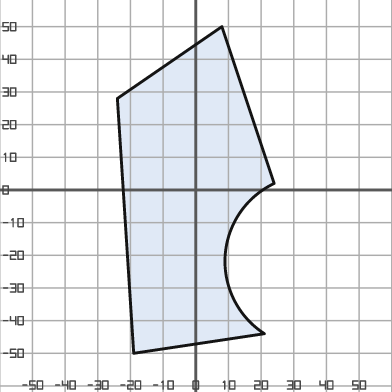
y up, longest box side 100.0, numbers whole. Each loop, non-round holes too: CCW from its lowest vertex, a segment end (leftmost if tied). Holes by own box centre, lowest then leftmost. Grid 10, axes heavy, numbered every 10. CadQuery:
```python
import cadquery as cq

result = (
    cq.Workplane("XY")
    .moveTo(-19.0, -50.0)
    .lineTo(21.0, -44.0)
    .threePointArc((9.0, -20.0), (24.0, 2.0))
    .lineTo(8.0, 50.0)
    .lineTo(-24.0, 28.0)
    .close()
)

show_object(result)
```